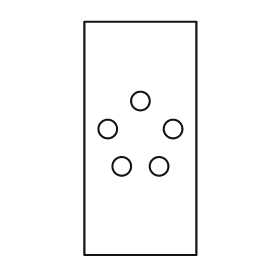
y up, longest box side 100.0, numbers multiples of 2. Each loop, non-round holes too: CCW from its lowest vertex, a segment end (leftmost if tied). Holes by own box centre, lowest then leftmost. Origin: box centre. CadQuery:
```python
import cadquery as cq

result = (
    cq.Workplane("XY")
    .moveTo(-24.0, -50.0)
    .lineTo(24.0, -50.0)
    .lineTo(24.0, 50.0)
    .lineTo(-24.0, 50.0)
    .close()
    .moveTo(-8.0, -12.0)
    .circle(4.0)
    .moveTo(8.0, -12.0)
    .circle(4.0)
    .moveTo(-14.0, 4.0)
    .circle(4.0)
    .moveTo(14.0, 4.0)
    .circle(4.0)
    .moveTo(0.0, 16.0)
    .circle(4.0)
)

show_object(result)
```